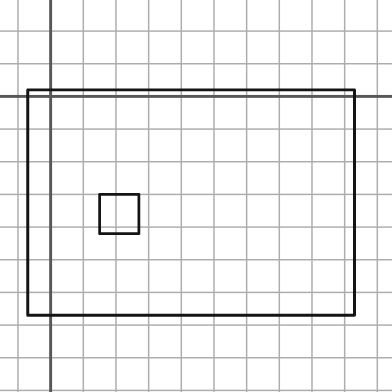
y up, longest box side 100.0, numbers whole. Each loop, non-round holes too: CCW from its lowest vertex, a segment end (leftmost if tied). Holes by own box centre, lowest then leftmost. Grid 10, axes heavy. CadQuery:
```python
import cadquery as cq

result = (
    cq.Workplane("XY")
    .moveTo(-7.0, -67.0)
    .lineTo(93.0, -67.0)
    .lineTo(93.0, 2.0)
    .lineTo(-7.0, 2.0)
    .close()
    .moveTo(15.0, -42.0)
    .lineTo(27.0, -42.0)
    .lineTo(27.0, -30.0)
    .lineTo(15.0, -30.0)
    .close()
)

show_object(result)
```